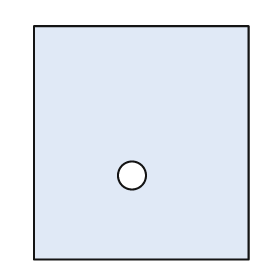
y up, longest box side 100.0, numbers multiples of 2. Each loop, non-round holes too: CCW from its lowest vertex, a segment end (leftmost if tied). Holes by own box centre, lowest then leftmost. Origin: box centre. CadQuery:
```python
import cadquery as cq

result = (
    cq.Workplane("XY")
    .moveTo(-46.0, -50.0)
    .lineTo(46.0, -50.0)
    .lineTo(46.0, 50.0)
    .lineTo(-46.0, 50.0)
    .close()
    .moveTo(-4.0, -14.0)
    .circle(6.0)
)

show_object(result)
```